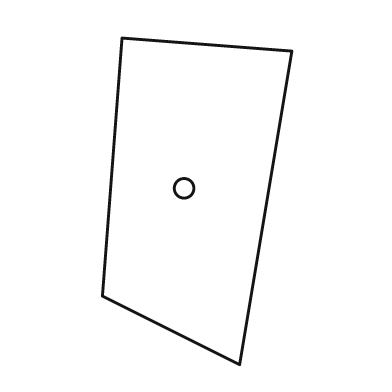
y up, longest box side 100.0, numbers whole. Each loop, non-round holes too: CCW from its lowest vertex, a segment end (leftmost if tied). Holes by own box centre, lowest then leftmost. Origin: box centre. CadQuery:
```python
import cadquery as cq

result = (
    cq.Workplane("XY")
    .moveTo(13.0, -50.0)
    .lineTo(29.0, 46.0)
    .lineTo(-23.0, 50.0)
    .lineTo(-29.0, -29.0)
    .close()
    .moveTo(-4.0, 4.0)
    .circle(3.0)
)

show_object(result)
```